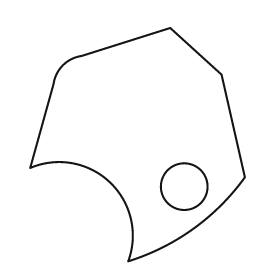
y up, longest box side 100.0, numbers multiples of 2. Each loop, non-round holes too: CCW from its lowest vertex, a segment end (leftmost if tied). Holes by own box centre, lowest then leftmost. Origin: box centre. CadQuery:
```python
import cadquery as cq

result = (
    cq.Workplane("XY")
    .moveTo(-4.0, -50.0)
    .threePointArc((24.0, -36.0), (46.0, -14.0))
    .lineTo(36.0, 30.0)
    .lineTo(14.0, 50.0)
    .lineTo(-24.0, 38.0)
    .threePointArc((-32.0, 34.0), (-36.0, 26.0))
    .lineTo(-46.0, -10.0)
    .threePointArc((-12.0, -16.0), (-4.0, -50.0))
    .close()
    .moveTo(20.0, -18.0)
    .circle(10.0)
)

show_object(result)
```